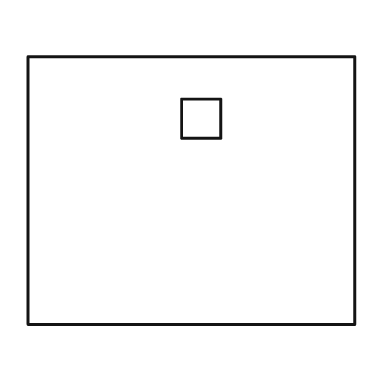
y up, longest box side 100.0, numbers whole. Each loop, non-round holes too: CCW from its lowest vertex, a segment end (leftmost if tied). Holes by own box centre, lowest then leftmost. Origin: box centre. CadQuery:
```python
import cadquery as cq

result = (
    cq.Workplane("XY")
    .moveTo(-50.0, -41.0)
    .lineTo(50.0, -41.0)
    .lineTo(50.0, 41.0)
    .lineTo(-50.0, 41.0)
    .close()
    .moveTo(-3.0, 16.0)
    .lineTo(9.0, 16.0)
    .lineTo(9.0, 28.0)
    .lineTo(-3.0, 28.0)
    .close()
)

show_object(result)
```